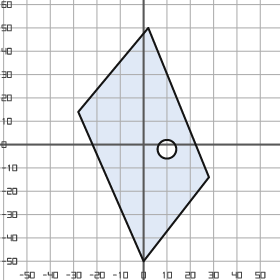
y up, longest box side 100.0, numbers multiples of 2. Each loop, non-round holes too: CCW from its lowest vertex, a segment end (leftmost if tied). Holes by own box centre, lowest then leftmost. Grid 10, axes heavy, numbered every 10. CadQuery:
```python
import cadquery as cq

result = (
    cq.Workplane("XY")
    .moveTo(0.0, -50.0)
    .lineTo(28.0, -14.0)
    .lineTo(2.0, 50.0)
    .lineTo(-28.0, 14.0)
    .close()
    .moveTo(10.0, -2.0)
    .circle(4.0)
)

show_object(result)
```